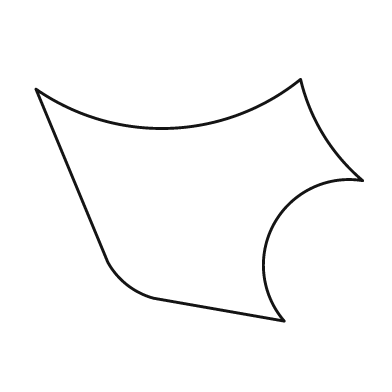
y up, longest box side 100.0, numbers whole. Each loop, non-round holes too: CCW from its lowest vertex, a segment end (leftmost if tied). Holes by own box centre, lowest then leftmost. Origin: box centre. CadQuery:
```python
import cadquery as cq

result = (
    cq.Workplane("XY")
    .moveTo(26.0, -37.0)
    .threePointArc((23.0, -7.0), (50.0, 6.0))
    .threePointArc((38.0, 20.0), (31.0, 37.0))
    .threePointArc((-9.0, 22.0), (-50.0, 34.0))
    .lineTo(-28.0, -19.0)
    .threePointArc((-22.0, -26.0), (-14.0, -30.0))
    .close()
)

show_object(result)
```